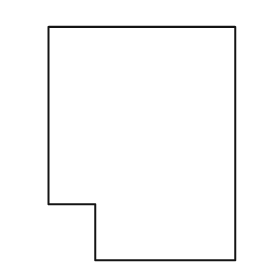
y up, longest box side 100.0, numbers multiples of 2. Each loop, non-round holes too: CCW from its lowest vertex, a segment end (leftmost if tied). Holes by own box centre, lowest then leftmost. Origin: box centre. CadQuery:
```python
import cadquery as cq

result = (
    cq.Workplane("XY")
    .moveTo(-20.0, -50.0)
    .lineTo(40.0, -50.0)
    .lineTo(40.0, 50.0)
    .lineTo(-40.0, 50.0)
    .lineTo(-40.0, -26.0)
    .lineTo(-20.0, -26.0)
    .close()
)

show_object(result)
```